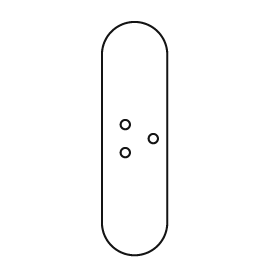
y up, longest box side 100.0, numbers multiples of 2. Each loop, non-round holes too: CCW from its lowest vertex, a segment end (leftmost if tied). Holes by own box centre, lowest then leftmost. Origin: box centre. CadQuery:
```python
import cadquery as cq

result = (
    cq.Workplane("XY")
    .moveTo(-14.0, -36.0)
    .threePointArc((0.0, -50.0), (14.0, -36.0))
    .lineTo(14.0, 36.0)
    .threePointArc((0.0, 50.0), (-14.0, 36.0))
    .close()
    .moveTo(-4.0, -6.0)
    .circle(2.0)
    .moveTo(8.0, 0.0)
    .circle(2.0)
    .moveTo(-4.0, 6.0)
    .circle(2.0)
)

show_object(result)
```